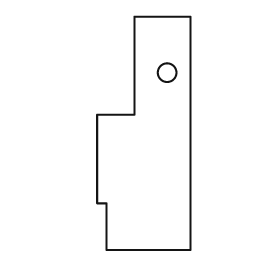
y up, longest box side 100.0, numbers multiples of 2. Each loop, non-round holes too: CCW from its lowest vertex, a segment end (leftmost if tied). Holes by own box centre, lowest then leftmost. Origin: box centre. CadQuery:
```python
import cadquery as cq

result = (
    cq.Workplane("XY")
    .moveTo(-16.0, -50.0)
    .lineTo(20.0, -50.0)
    .lineTo(20.0, 50.0)
    .lineTo(-4.0, 50.0)
    .lineTo(-4.0, 8.0)
    .lineTo(-20.0, 8.0)
    .lineTo(-20.0, -30.0)
    .lineTo(-16.0, -30.0)
    .close()
    .moveTo(10.0, 26.0)
    .circle(4.0)
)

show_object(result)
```